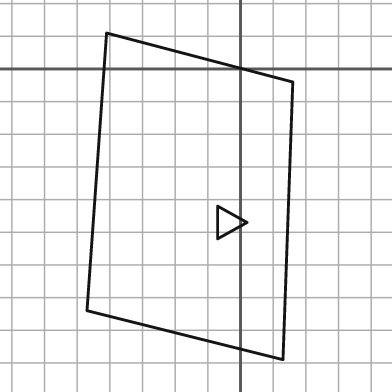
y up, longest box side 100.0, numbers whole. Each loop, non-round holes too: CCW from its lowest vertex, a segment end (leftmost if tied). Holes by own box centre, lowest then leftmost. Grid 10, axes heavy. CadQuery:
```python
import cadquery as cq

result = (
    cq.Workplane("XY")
    .moveTo(13.0, -89.0)
    .lineTo(16.0, -4.0)
    .lineTo(-41.0, 11.0)
    .lineTo(-47.0, -74.0)
    .close()
    .moveTo(-7.0, -52.0)
    .lineTo(2.0, -47.0)
    .lineTo(-7.0, -42.0)
    .close()
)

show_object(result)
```